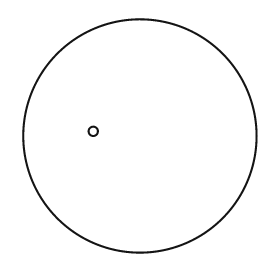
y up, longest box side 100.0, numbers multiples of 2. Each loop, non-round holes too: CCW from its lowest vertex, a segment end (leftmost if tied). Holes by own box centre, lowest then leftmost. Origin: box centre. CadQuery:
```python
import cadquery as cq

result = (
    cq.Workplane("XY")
    .moveTo(0.0, 0.0)
    .circle(50.0)
    .moveTo(-20.0, 2.0)
    .circle(2.0)
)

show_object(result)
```